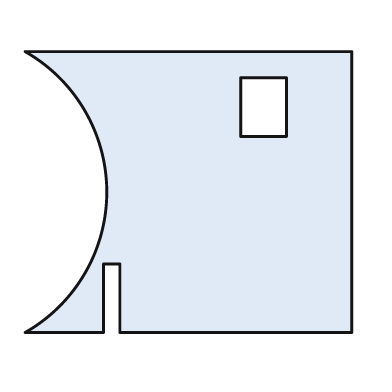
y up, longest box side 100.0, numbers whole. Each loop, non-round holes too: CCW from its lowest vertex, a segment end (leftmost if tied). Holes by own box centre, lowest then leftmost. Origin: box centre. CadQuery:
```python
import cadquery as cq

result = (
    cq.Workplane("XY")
    .moveTo(-50.0, -43.0)
    .lineTo(-26.0, -43.0)
    .lineTo(-26.0, -22.0)
    .lineTo(-21.0, -22.0)
    .lineTo(-21.0, -43.0)
    .lineTo(50.0, -43.0)
    .lineTo(50.0, 43.0)
    .lineTo(-50.0, 43.0)
    .threePointArc((-25.0, 0.0), (-50.0, -43.0))
    .close()
    .moveTo(16.0, 17.0)
    .lineTo(30.0, 17.0)
    .lineTo(30.0, 35.0)
    .lineTo(16.0, 35.0)
    .close()
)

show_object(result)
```